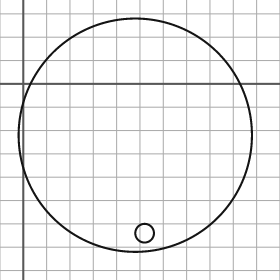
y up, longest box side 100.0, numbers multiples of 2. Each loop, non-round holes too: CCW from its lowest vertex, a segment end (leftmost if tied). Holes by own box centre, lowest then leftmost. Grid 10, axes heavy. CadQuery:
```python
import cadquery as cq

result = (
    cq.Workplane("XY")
    .moveTo(48.0, -22.0)
    .circle(50.0)
    .moveTo(52.0, -64.0)
    .circle(4.0)
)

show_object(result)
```